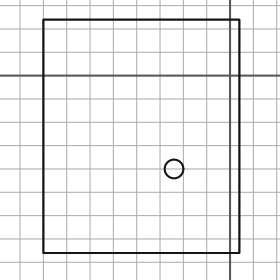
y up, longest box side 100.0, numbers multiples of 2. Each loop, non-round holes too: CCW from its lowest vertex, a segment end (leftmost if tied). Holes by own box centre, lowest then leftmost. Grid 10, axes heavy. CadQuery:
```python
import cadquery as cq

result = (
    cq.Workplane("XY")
    .moveTo(-80.0, -76.0)
    .lineTo(4.0, -76.0)
    .lineTo(4.0, 24.0)
    .lineTo(-80.0, 24.0)
    .close()
    .moveTo(-24.0, -40.0)
    .circle(4.0)
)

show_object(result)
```